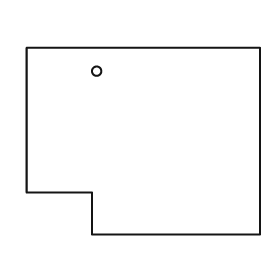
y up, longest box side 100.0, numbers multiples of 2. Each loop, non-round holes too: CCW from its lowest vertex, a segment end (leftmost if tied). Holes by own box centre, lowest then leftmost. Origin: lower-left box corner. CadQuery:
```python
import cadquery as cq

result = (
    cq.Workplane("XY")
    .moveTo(28.0, 0.0)
    .lineTo(100.0, 0.0)
    .lineTo(100.0, 80.0)
    .lineTo(0.0, 80.0)
    .lineTo(0.0, 18.0)
    .lineTo(28.0, 18.0)
    .close()
    .moveTo(30.0, 70.0)
    .circle(2.0)
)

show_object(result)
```